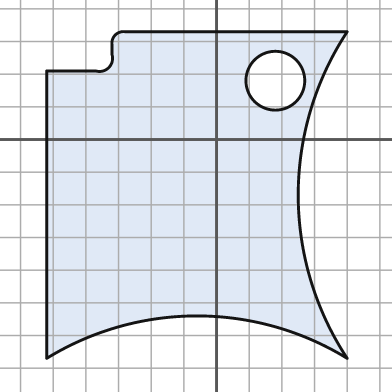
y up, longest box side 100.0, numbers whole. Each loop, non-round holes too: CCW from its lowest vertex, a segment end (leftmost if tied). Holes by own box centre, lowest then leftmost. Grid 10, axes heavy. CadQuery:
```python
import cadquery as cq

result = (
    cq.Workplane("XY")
    .moveTo(-52.0, -67.0)
    .threePointArc((-6.0, -54.0), (40.0, -67.0))
    .threePointArc((25.0, -17.0), (40.0, 33.0))
    .lineTo(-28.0, 33.0)
    .threePointArc((-31.0, 32.0), (-32.0, 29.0))
    .lineTo(-32.0, 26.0)
    .threePointArc((-33.0, 22.0), (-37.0, 21.0))
    .lineTo(-52.0, 21.0)
    .close()
    .moveTo(18.0, 18.0)
    .circle(9.0)
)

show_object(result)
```